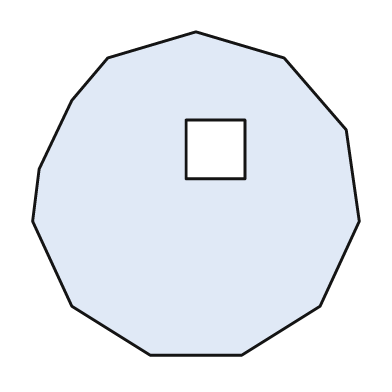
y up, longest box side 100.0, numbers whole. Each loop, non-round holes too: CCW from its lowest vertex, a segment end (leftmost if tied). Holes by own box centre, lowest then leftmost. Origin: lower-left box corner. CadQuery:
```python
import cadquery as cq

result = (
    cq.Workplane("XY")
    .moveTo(36.0, 0.0)
    .lineTo(64.0, 0.0)
    .lineTo(88.0, 15.0)
    .lineTo(100.0, 41.0)
    .lineTo(96.0, 69.0)
    .lineTo(77.0, 91.0)
    .lineTo(50.0, 99.0)
    .lineTo(23.0, 91.0)
    .lineTo(12.0, 78.0)
    .lineTo(2.0, 57.0)
    .lineTo(0.0, 41.0)
    .lineTo(12.0, 15.0)
    .close()
    .moveTo(47.0, 54.0)
    .lineTo(65.0, 54.0)
    .lineTo(65.0, 72.0)
    .lineTo(47.0, 72.0)
    .close()
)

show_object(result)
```